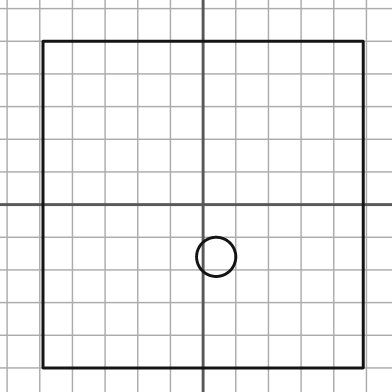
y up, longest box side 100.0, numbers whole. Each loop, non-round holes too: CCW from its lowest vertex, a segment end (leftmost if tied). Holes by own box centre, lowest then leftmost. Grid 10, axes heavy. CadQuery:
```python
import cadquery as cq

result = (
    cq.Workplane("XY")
    .moveTo(-49.0, -50.0)
    .lineTo(49.0, -50.0)
    .lineTo(49.0, 50.0)
    .lineTo(-49.0, 50.0)
    .close()
    .moveTo(4.0, -16.0)
    .circle(6.0)
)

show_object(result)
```